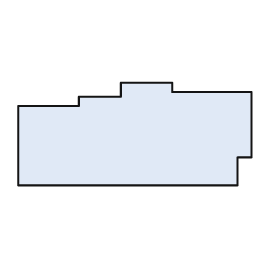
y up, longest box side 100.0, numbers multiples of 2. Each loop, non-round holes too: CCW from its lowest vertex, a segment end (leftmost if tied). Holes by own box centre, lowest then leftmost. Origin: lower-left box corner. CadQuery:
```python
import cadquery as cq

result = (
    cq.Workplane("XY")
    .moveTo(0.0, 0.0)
    .lineTo(94.0, 0.0)
    .lineTo(94.0, 12.0)
    .lineTo(100.0, 12.0)
    .lineTo(100.0, 40.0)
    .lineTo(66.0, 40.0)
    .lineTo(66.0, 44.0)
    .lineTo(44.0, 44.0)
    .lineTo(44.0, 38.0)
    .lineTo(26.0, 38.0)
    .lineTo(26.0, 34.0)
    .lineTo(0.0, 34.0)
    .close()
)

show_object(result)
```